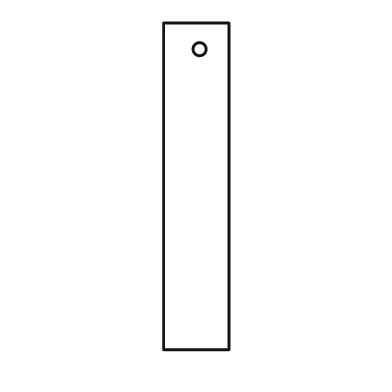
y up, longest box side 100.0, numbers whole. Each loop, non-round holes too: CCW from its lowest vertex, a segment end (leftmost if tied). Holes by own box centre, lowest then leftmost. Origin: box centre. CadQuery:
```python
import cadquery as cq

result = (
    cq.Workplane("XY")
    .moveTo(-10.0, -50.0)
    .lineTo(10.0, -50.0)
    .lineTo(10.0, 50.0)
    .lineTo(-10.0, 50.0)
    .close()
    .moveTo(1.0, 42.0)
    .circle(2.0)
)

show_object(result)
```